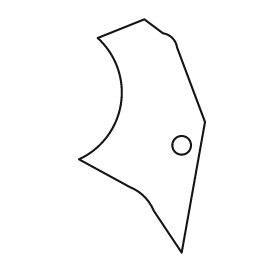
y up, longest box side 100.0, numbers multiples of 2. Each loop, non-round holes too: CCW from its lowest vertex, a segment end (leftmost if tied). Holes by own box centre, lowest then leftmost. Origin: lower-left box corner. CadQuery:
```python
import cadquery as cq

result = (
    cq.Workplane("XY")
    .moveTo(44.0, 0.0)
    .lineTo(54.0, 56.0)
    .lineTo(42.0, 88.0)
    .threePointArc((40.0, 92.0), (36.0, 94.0))
    .lineTo(28.0, 100.0)
    .lineTo(8.0, 92.0)
    .threePointArc((18.0, 64.0), (0.0, 40.0))
    .lineTo(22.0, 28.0)
    .threePointArc((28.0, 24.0), (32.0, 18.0))
    .close()
    .moveTo(44.0, 46.0)
    .circle(4.0)
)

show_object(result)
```